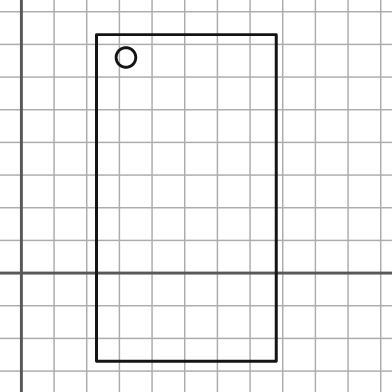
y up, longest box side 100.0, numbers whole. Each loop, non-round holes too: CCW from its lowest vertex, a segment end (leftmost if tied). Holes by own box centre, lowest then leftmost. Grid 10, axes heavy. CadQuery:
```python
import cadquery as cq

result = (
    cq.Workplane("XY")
    .moveTo(23.0, -27.0)
    .lineTo(78.0, -27.0)
    .lineTo(78.0, 73.0)
    .lineTo(23.0, 73.0)
    .close()
    .moveTo(32.0, 66.0)
    .circle(3.0)
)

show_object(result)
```